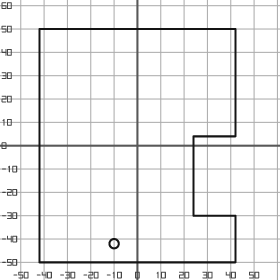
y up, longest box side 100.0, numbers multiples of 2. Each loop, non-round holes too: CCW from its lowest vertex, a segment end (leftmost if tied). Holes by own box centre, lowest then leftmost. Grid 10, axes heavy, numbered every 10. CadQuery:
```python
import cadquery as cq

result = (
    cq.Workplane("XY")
    .moveTo(-42.0, -50.0)
    .lineTo(42.0, -50.0)
    .lineTo(42.0, -30.0)
    .lineTo(24.0, -30.0)
    .lineTo(24.0, 4.0)
    .lineTo(42.0, 4.0)
    .lineTo(42.0, 50.0)
    .lineTo(-42.0, 50.0)
    .close()
    .moveTo(-10.0, -42.0)
    .circle(2.0)
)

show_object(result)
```